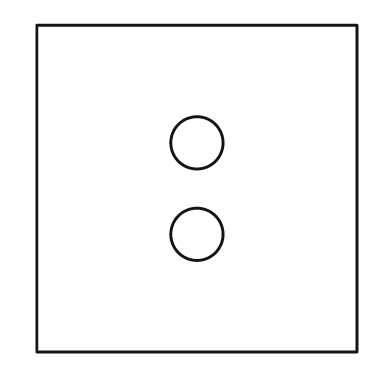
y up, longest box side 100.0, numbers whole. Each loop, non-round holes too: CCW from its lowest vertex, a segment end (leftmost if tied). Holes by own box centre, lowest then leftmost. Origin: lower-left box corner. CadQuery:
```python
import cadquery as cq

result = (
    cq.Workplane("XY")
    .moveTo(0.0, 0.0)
    .lineTo(98.0, 0.0)
    .lineTo(98.0, 100.0)
    .lineTo(0.0, 100.0)
    .close()
    .moveTo(49.0, 36.0)
    .circle(8.0)
    .moveTo(49.0, 64.0)
    .circle(8.0)
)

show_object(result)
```